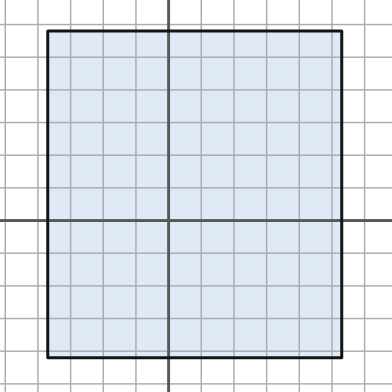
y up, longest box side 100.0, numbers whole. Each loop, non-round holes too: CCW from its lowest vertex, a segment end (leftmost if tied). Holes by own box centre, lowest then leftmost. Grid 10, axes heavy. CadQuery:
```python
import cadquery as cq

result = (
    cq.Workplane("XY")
    .moveTo(-37.0, -42.0)
    .lineTo(53.0, -42.0)
    .lineTo(53.0, 58.0)
    .lineTo(-37.0, 58.0)
    .close()
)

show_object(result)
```